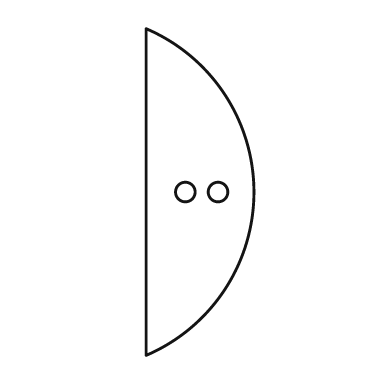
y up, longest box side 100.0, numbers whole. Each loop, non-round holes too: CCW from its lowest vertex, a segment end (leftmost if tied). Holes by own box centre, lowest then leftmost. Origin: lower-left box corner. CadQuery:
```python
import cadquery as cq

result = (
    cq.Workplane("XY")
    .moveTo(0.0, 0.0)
    .threePointArc((33.0, 50.0), (0.0, 100.0))
    .close()
    .moveTo(12.0, 50.0)
    .circle(3.0)
    .moveTo(22.0, 50.0)
    .circle(3.0)
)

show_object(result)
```